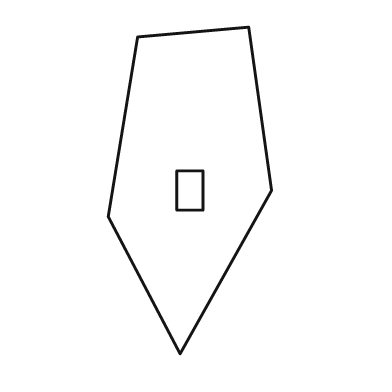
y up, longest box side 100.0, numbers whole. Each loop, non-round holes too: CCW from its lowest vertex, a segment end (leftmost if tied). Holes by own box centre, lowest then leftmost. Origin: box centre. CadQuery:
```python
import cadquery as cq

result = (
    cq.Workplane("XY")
    .moveTo(-3.0, -50.0)
    .lineTo(25.0, 0.0)
    .lineTo(18.0, 50.0)
    .lineTo(-16.0, 47.0)
    .lineTo(-25.0, -8.0)
    .close()
    .moveTo(-4.0, -6.0)
    .lineTo(4.0, -6.0)
    .lineTo(4.0, 6.0)
    .lineTo(-4.0, 6.0)
    .close()
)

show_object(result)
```